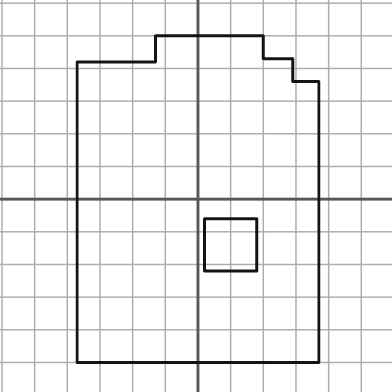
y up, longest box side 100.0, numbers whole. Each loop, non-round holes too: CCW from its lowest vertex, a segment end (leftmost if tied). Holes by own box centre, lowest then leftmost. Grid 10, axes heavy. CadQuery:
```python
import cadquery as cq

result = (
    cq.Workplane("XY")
    .moveTo(-37.0, -50.0)
    .lineTo(37.0, -50.0)
    .lineTo(37.0, 36.0)
    .lineTo(29.0, 36.0)
    .lineTo(29.0, 43.0)
    .lineTo(20.0, 43.0)
    .lineTo(20.0, 50.0)
    .lineTo(-13.0, 50.0)
    .lineTo(-13.0, 42.0)
    .lineTo(-37.0, 42.0)
    .close()
    .moveTo(2.0, -22.0)
    .lineTo(18.0, -22.0)
    .lineTo(18.0, -6.0)
    .lineTo(2.0, -6.0)
    .close()
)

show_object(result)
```